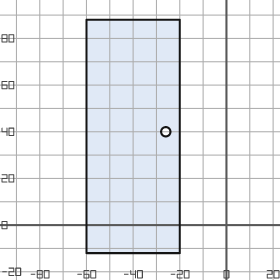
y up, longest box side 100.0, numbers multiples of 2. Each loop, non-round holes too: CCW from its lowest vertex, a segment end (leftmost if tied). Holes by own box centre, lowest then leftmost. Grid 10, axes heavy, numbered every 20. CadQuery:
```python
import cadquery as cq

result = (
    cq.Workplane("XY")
    .moveTo(-60.0, -12.0)
    .lineTo(-20.0, -12.0)
    .lineTo(-20.0, 88.0)
    .lineTo(-60.0, 88.0)
    .close()
    .moveTo(-26.0, 40.0)
    .circle(2.0)
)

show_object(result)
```